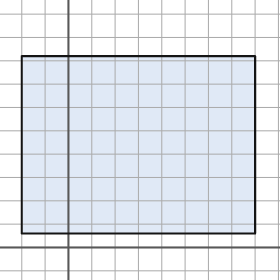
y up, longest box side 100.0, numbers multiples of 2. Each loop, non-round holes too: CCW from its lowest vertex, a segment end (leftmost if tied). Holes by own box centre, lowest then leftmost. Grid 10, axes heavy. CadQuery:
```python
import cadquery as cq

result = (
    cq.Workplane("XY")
    .moveTo(-20.0, 6.0)
    .lineTo(80.0, 6.0)
    .lineTo(80.0, 82.0)
    .lineTo(-20.0, 82.0)
    .close()
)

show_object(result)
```